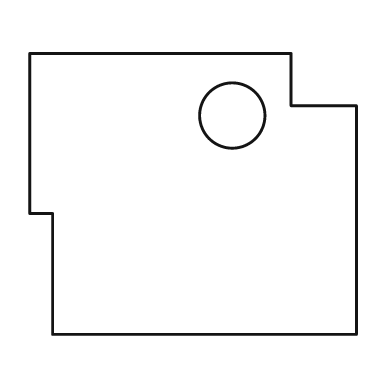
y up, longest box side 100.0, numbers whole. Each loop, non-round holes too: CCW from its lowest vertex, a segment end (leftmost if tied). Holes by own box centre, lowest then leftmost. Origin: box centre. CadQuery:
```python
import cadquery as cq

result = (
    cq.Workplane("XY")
    .moveTo(-43.0, -43.0)
    .lineTo(50.0, -43.0)
    .lineTo(50.0, 27.0)
    .lineTo(30.0, 27.0)
    .lineTo(30.0, 43.0)
    .lineTo(-50.0, 43.0)
    .lineTo(-50.0, -6.0)
    .lineTo(-43.0, -6.0)
    .close()
    .moveTo(12.0, 24.0)
    .circle(10.0)
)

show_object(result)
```